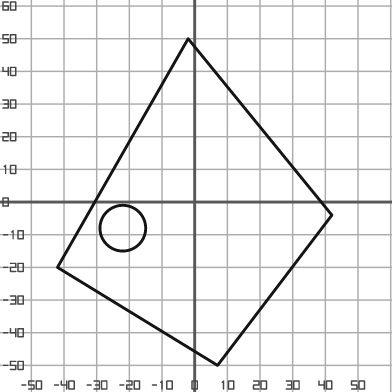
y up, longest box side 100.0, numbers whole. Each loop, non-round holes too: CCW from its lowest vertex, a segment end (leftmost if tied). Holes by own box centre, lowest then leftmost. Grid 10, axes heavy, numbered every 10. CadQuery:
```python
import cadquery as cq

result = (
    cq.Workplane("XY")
    .moveTo(7.0, -50.0)
    .lineTo(42.0, -4.0)
    .lineTo(-2.0, 50.0)
    .lineTo(-42.0, -20.0)
    .close()
    .moveTo(-22.0, -8.0)
    .circle(7.0)
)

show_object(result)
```